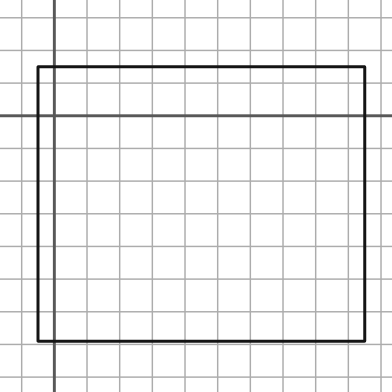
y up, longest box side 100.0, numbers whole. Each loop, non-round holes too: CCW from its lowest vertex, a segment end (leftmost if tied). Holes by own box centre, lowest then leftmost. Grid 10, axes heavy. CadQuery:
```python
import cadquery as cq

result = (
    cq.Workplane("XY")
    .moveTo(-5.0, -69.0)
    .lineTo(95.0, -69.0)
    .lineTo(95.0, 15.0)
    .lineTo(-5.0, 15.0)
    .close()
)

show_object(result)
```